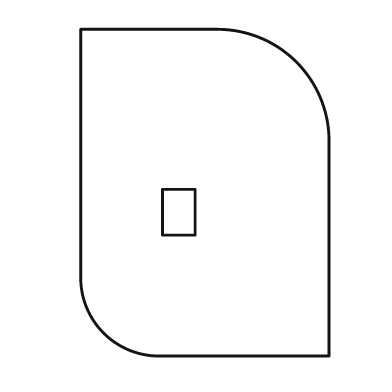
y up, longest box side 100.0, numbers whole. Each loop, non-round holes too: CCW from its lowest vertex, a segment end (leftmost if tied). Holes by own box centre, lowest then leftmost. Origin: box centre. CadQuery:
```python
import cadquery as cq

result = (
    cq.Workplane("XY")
    .moveTo(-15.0, -50.0)
    .lineTo(38.0, -50.0)
    .lineTo(38.0, 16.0)
    .threePointArc((28.0, 40.0), (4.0, 50.0))
    .lineTo(-38.0, 50.0)
    .lineTo(-38.0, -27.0)
    .threePointArc((-31.0, -43.0), (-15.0, -50.0))
    .close()
    .moveTo(-13.0, -13.0)
    .lineTo(-3.0, -13.0)
    .lineTo(-3.0, 1.0)
    .lineTo(-13.0, 1.0)
    .close()
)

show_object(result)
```